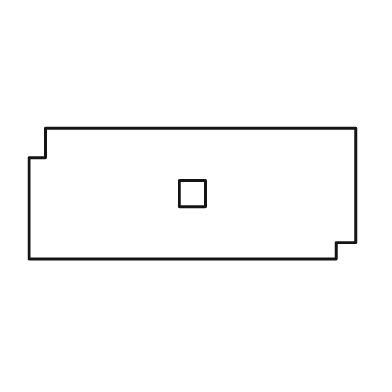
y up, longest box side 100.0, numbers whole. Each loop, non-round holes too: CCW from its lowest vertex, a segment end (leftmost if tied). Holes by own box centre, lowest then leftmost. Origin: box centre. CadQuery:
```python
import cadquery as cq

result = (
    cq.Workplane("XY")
    .moveTo(-50.0, -20.0)
    .lineTo(44.0, -20.0)
    .lineTo(44.0, -15.0)
    .lineTo(50.0, -15.0)
    .lineTo(50.0, 20.0)
    .lineTo(-45.0, 20.0)
    .lineTo(-45.0, 11.0)
    .lineTo(-50.0, 11.0)
    .close()
    .moveTo(-4.0, -4.0)
    .lineTo(4.0, -4.0)
    .lineTo(4.0, 4.0)
    .lineTo(-4.0, 4.0)
    .close()
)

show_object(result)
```